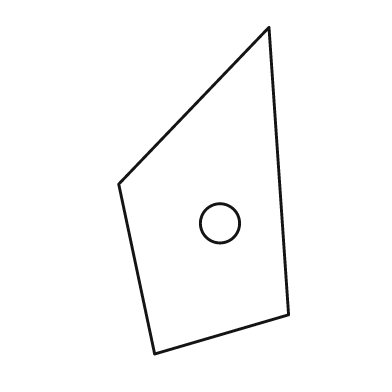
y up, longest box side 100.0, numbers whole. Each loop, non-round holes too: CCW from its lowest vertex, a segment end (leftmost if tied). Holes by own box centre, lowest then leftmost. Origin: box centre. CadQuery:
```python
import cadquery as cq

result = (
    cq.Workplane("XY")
    .moveTo(-15.0, -50.0)
    .lineTo(26.0, -38.0)
    .lineTo(20.0, 50.0)
    .lineTo(-26.0, 2.0)
    .close()
    .moveTo(5.0, -10.0)
    .circle(6.0)
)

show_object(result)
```